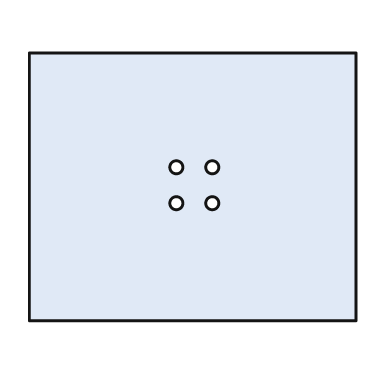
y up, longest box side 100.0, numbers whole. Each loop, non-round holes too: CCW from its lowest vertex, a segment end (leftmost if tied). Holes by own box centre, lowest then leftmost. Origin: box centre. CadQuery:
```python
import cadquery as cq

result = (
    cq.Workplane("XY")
    .moveTo(-50.0, -41.0)
    .lineTo(50.0, -41.0)
    .lineTo(50.0, 41.0)
    .lineTo(-50.0, 41.0)
    .close()
    .moveTo(-5.0, -5.0)
    .circle(2.0)
    .moveTo(6.0, -5.0)
    .circle(2.0)
    .moveTo(-5.0, 6.0)
    .circle(2.0)
    .moveTo(6.0, 6.0)
    .circle(2.0)
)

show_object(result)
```